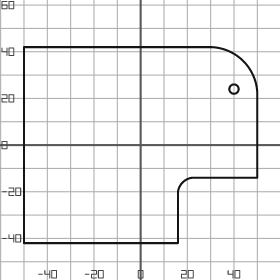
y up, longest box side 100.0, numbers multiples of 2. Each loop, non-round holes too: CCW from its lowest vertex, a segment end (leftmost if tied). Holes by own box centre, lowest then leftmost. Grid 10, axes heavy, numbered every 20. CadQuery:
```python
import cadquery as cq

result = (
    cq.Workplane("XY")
    .moveTo(-50.0, -42.0)
    .lineTo(16.0, -42.0)
    .lineTo(16.0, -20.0)
    .threePointArc((18.0, -16.0), (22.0, -14.0))
    .lineTo(50.0, -14.0)
    .lineTo(50.0, 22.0)
    .threePointArc((44.0, 36.0), (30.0, 42.0))
    .lineTo(-50.0, 42.0)
    .close()
    .moveTo(40.0, 24.0)
    .circle(2.0)
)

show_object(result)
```